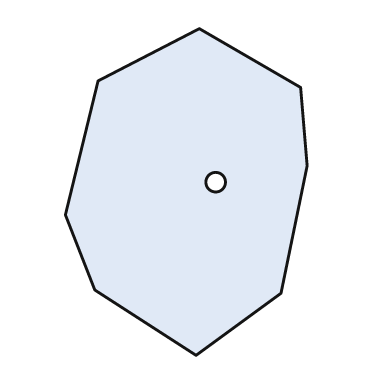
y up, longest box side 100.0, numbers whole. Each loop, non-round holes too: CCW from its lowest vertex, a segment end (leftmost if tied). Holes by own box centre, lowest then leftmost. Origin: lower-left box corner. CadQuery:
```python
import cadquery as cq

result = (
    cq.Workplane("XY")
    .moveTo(40.0, 0.0)
    .lineTo(66.0, 19.0)
    .lineTo(74.0, 58.0)
    .lineTo(72.0, 82.0)
    .lineTo(41.0, 100.0)
    .lineTo(10.0, 84.0)
    .lineTo(0.0, 43.0)
    .lineTo(9.0, 20.0)
    .close()
    .moveTo(46.0, 53.0)
    .circle(3.0)
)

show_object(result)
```